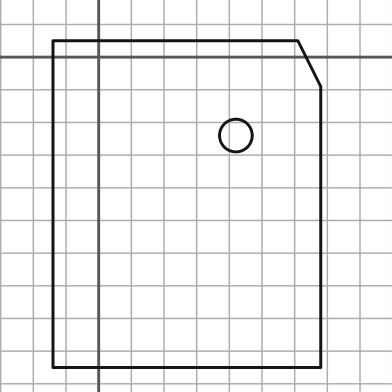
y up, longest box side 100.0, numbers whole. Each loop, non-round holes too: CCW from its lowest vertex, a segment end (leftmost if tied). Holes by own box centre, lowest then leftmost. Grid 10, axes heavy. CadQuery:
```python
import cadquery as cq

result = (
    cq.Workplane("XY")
    .moveTo(-14.0, -95.0)
    .lineTo(68.0, -95.0)
    .lineTo(68.0, -9.0)
    .lineTo(61.0, 5.0)
    .lineTo(-14.0, 5.0)
    .close()
    .moveTo(42.0, -24.0)
    .circle(5.0)
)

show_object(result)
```